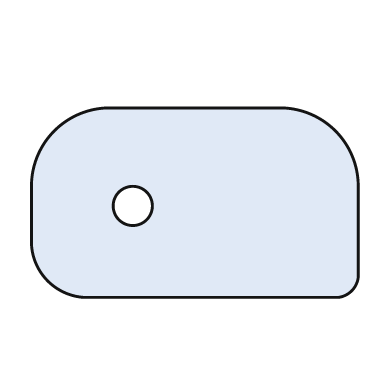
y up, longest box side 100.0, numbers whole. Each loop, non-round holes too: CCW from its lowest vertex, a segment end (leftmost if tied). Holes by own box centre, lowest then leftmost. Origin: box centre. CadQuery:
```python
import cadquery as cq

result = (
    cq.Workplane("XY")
    .moveTo(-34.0, -29.0)
    .lineTo(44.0, -29.0)
    .threePointArc((48.0, -27.0), (50.0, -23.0))
    .lineTo(50.0, 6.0)
    .threePointArc((43.0, 22.0), (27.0, 29.0))
    .lineTo(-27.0, 29.0)
    .threePointArc((-43.0, 22.0), (-50.0, 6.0))
    .lineTo(-50.0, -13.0)
    .threePointArc((-45.0, -24.0), (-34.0, -29.0))
    .close()
    .moveTo(-19.0, -1.0)
    .circle(6.0)
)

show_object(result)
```